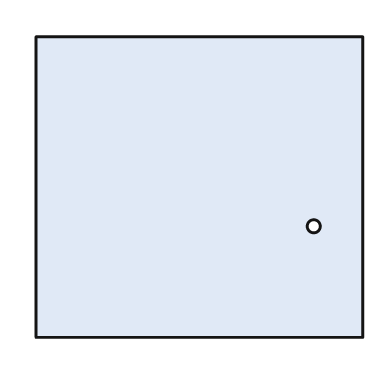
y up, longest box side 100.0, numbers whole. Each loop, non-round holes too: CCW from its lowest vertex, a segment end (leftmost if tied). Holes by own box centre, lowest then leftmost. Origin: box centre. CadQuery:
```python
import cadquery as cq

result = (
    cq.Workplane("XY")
    .moveTo(-50.0, -46.0)
    .lineTo(50.0, -46.0)
    .lineTo(50.0, 46.0)
    .lineTo(-50.0, 46.0)
    .close()
    .moveTo(35.0, -12.0)
    .circle(2.0)
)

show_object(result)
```